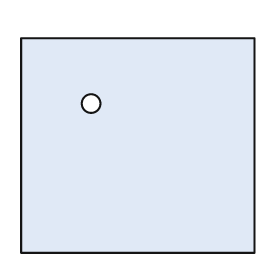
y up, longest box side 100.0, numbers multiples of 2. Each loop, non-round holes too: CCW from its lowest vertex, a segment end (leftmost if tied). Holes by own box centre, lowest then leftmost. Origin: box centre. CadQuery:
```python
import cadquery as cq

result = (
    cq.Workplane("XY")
    .moveTo(-50.0, -46.0)
    .lineTo(50.0, -46.0)
    .lineTo(50.0, 46.0)
    .lineTo(-50.0, 46.0)
    .close()
    .moveTo(-20.0, 18.0)
    .circle(4.0)
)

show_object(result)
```